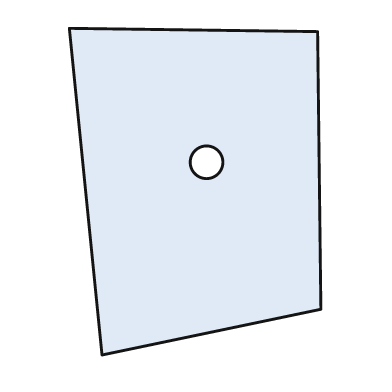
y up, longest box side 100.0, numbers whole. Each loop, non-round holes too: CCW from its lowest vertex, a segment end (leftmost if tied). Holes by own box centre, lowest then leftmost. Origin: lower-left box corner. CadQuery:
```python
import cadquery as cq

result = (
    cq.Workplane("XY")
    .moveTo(10.0, 0.0)
    .lineTo(77.0, 14.0)
    .lineTo(76.0, 99.0)
    .lineTo(0.0, 100.0)
    .close()
    .moveTo(42.0, 59.0)
    .circle(5.0)
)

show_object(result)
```